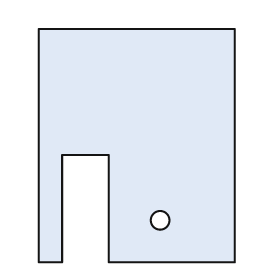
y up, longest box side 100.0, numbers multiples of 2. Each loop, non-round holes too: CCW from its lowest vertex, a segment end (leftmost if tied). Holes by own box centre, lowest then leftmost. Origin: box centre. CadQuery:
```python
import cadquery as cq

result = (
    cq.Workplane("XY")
    .moveTo(-42.0, -50.0)
    .lineTo(-32.0, -50.0)
    .lineTo(-32.0, -4.0)
    .lineTo(-12.0, -4.0)
    .lineTo(-12.0, -50.0)
    .lineTo(42.0, -50.0)
    .lineTo(42.0, 50.0)
    .lineTo(-42.0, 50.0)
    .close()
    .moveTo(10.0, -32.0)
    .circle(4.0)
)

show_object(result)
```